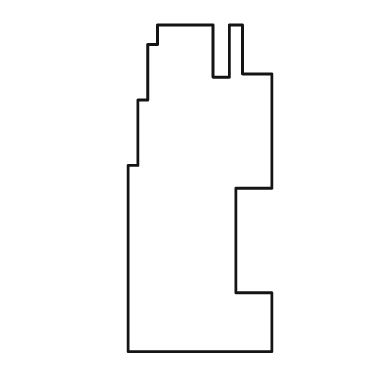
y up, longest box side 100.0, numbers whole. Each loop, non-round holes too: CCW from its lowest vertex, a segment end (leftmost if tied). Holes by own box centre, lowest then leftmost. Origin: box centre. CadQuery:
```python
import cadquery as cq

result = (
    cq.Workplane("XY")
    .moveTo(-22.0, -50.0)
    .lineTo(22.0, -50.0)
    .lineTo(22.0, -32.0)
    .lineTo(11.0, -32.0)
    .lineTo(11.0, 0.0)
    .lineTo(22.0, 0.0)
    .lineTo(22.0, 35.0)
    .lineTo(13.0, 35.0)
    .lineTo(13.0, 50.0)
    .lineTo(9.0, 50.0)
    .lineTo(9.0, 34.0)
    .lineTo(4.0, 34.0)
    .lineTo(4.0, 50.0)
    .lineTo(-13.0, 50.0)
    .lineTo(-13.0, 44.0)
    .lineTo(-16.0, 44.0)
    .lineTo(-16.0, 27.0)
    .lineTo(-19.0, 27.0)
    .lineTo(-19.0, 7.0)
    .lineTo(-22.0, 7.0)
    .close()
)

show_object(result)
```